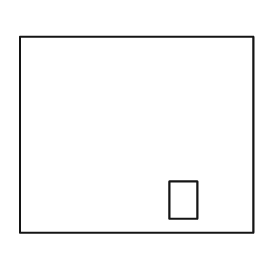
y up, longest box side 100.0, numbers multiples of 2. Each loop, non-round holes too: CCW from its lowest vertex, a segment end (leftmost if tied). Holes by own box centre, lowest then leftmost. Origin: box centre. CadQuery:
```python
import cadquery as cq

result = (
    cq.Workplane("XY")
    .moveTo(-50.0, -42.0)
    .lineTo(50.0, -42.0)
    .lineTo(50.0, 42.0)
    .lineTo(-50.0, 42.0)
    .close()
    .moveTo(14.0, -36.0)
    .lineTo(26.0, -36.0)
    .lineTo(26.0, -20.0)
    .lineTo(14.0, -20.0)
    .close()
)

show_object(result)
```